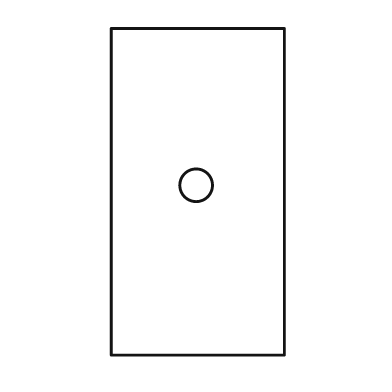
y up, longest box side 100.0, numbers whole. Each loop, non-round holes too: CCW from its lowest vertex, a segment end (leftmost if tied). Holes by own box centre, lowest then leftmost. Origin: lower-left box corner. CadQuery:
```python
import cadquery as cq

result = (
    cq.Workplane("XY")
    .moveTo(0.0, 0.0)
    .lineTo(53.0, 0.0)
    .lineTo(53.0, 100.0)
    .lineTo(0.0, 100.0)
    .close()
    .moveTo(26.0, 52.0)
    .circle(5.0)
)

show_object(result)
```